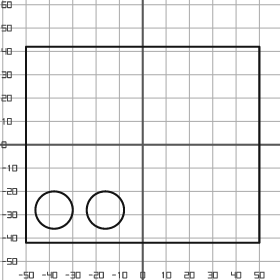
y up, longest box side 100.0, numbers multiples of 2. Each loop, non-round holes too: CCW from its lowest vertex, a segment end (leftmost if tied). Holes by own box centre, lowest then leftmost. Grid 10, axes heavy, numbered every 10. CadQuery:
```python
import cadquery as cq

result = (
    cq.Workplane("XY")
    .moveTo(-50.0, -42.0)
    .lineTo(50.0, -42.0)
    .lineTo(50.0, 42.0)
    .lineTo(-50.0, 42.0)
    .close()
    .moveTo(-38.0, -28.0)
    .circle(8.0)
    .moveTo(-16.0, -28.0)
    .circle(8.0)
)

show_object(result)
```